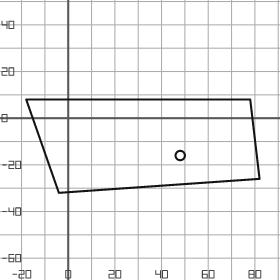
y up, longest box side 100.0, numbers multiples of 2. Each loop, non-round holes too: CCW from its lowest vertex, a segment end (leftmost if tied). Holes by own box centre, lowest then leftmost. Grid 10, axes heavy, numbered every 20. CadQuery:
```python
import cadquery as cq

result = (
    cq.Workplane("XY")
    .moveTo(-4.0, -32.0)
    .lineTo(82.0, -26.0)
    .lineTo(78.0, 8.0)
    .lineTo(-18.0, 8.0)
    .close()
    .moveTo(48.0, -16.0)
    .circle(2.0)
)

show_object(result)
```